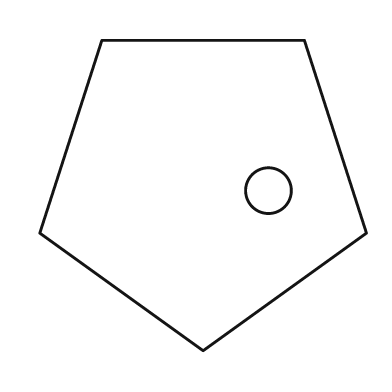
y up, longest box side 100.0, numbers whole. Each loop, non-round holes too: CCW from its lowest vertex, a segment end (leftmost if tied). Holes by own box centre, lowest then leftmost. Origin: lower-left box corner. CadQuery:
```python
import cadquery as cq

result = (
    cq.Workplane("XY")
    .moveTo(50.0, 0.0)
    .lineTo(100.0, 36.0)
    .lineTo(81.0, 95.0)
    .lineTo(19.0, 95.0)
    .lineTo(0.0, 36.0)
    .close()
    .moveTo(70.0, 49.0)
    .circle(7.0)
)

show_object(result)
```